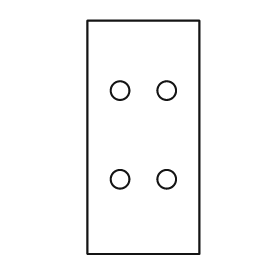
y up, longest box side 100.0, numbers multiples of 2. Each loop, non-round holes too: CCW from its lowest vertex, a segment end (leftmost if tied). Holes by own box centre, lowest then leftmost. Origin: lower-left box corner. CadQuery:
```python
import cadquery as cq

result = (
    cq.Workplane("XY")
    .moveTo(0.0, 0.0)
    .lineTo(48.0, 0.0)
    .lineTo(48.0, 100.0)
    .lineTo(0.0, 100.0)
    .close()
    .moveTo(14.0, 32.0)
    .circle(4.0)
    .moveTo(34.0, 32.0)
    .circle(4.0)
    .moveTo(14.0, 70.0)
    .circle(4.0)
    .moveTo(34.0, 70.0)
    .circle(4.0)
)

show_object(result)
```